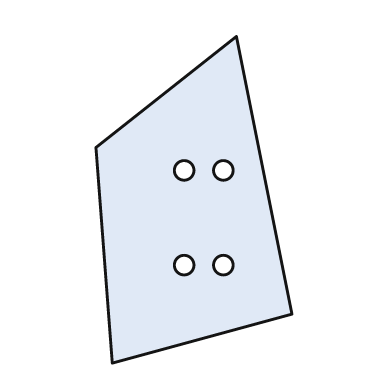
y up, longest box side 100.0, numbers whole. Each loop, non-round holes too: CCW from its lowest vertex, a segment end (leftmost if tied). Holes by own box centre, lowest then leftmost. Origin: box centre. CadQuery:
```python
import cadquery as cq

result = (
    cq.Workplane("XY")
    .moveTo(-25.0, -50.0)
    .lineTo(30.0, -35.0)
    .lineTo(13.0, 50.0)
    .lineTo(-30.0, 16.0)
    .close()
    .moveTo(-3.0, -20.0)
    .circle(3.0)
    .moveTo(9.0, -20.0)
    .circle(3.0)
    .moveTo(-3.0, 9.0)
    .circle(3.0)
    .moveTo(9.0, 9.0)
    .circle(3.0)
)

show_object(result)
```